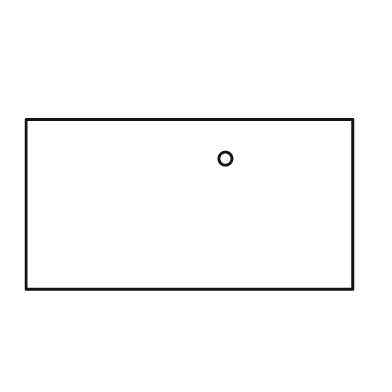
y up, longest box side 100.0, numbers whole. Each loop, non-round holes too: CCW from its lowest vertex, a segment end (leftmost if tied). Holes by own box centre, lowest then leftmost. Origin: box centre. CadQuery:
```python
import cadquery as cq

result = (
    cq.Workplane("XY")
    .moveTo(-50.0, -26.0)
    .lineTo(50.0, -26.0)
    .lineTo(50.0, 26.0)
    .lineTo(-50.0, 26.0)
    .close()
    .moveTo(11.0, 14.0)
    .circle(2.0)
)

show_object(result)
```